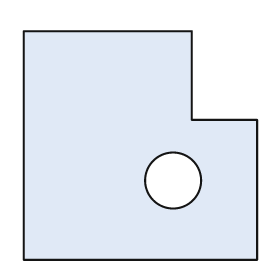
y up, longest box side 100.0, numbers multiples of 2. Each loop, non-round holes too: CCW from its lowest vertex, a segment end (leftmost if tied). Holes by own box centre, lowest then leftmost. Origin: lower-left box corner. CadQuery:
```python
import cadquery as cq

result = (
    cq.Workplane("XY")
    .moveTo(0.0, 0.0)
    .lineTo(100.0, 0.0)
    .lineTo(100.0, 60.0)
    .lineTo(72.0, 60.0)
    .lineTo(72.0, 98.0)
    .lineTo(0.0, 98.0)
    .close()
    .moveTo(64.0, 34.0)
    .circle(12.0)
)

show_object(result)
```